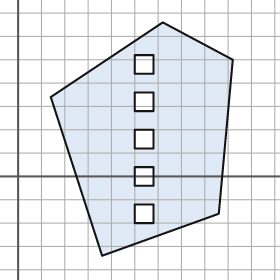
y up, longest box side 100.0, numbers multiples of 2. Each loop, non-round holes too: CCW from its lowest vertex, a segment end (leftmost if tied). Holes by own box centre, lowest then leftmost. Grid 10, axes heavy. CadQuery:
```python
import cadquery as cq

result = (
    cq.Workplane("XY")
    .moveTo(36.0, -34.0)
    .lineTo(86.0, -16.0)
    .lineTo(92.0, 50.0)
    .lineTo(62.0, 66.0)
    .lineTo(14.0, 34.0)
    .close()
    .moveTo(50.0, -20.0)
    .lineTo(58.0, -20.0)
    .lineTo(58.0, -12.0)
    .lineTo(50.0, -12.0)
    .close()
    .moveTo(50.0, -4.0)
    .lineTo(58.0, -4.0)
    .lineTo(58.0, 4.0)
    .lineTo(50.0, 4.0)
    .close()
    .moveTo(50.0, 12.0)
    .lineTo(58.0, 12.0)
    .lineTo(58.0, 20.0)
    .lineTo(50.0, 20.0)
    .close()
    .moveTo(50.0, 28.0)
    .lineTo(58.0, 28.0)
    .lineTo(58.0, 36.0)
    .lineTo(50.0, 36.0)
    .close()
    .moveTo(50.0, 44.0)
    .lineTo(58.0, 44.0)
    .lineTo(58.0, 52.0)
    .lineTo(50.0, 52.0)
    .close()
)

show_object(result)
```